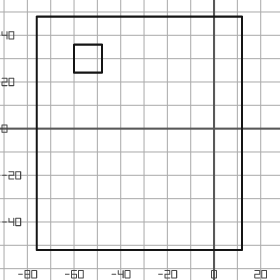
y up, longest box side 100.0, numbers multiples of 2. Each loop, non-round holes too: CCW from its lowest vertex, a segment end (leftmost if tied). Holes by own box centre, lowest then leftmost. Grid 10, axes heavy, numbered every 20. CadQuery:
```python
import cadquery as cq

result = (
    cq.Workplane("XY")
    .moveTo(-76.0, -52.0)
    .lineTo(12.0, -52.0)
    .lineTo(12.0, 48.0)
    .lineTo(-76.0, 48.0)
    .close()
    .moveTo(-60.0, 24.0)
    .lineTo(-48.0, 24.0)
    .lineTo(-48.0, 36.0)
    .lineTo(-60.0, 36.0)
    .close()
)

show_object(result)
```